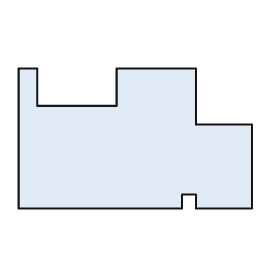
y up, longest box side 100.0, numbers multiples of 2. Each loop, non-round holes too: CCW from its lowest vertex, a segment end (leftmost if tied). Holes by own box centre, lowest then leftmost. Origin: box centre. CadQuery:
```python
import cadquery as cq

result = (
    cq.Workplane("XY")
    .moveTo(-50.0, -30.0)
    .lineTo(20.0, -30.0)
    .lineTo(20.0, -24.0)
    .lineTo(26.0, -24.0)
    .lineTo(26.0, -30.0)
    .lineTo(50.0, -30.0)
    .lineTo(50.0, 6.0)
    .lineTo(26.0, 6.0)
    .lineTo(26.0, 30.0)
    .lineTo(-8.0, 30.0)
    .lineTo(-8.0, 14.0)
    .lineTo(-42.0, 14.0)
    .lineTo(-42.0, 30.0)
    .lineTo(-50.0, 30.0)
    .close()
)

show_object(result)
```